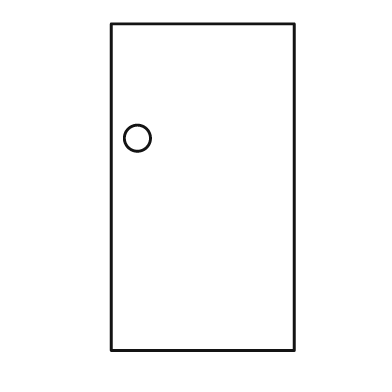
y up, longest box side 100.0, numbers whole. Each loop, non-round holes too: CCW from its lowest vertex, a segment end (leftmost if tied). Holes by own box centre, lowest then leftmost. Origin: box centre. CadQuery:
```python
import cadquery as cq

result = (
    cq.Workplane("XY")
    .moveTo(-28.0, -50.0)
    .lineTo(28.0, -50.0)
    .lineTo(28.0, 50.0)
    .lineTo(-28.0, 50.0)
    .close()
    .moveTo(-20.0, 15.0)
    .circle(4.0)
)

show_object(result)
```